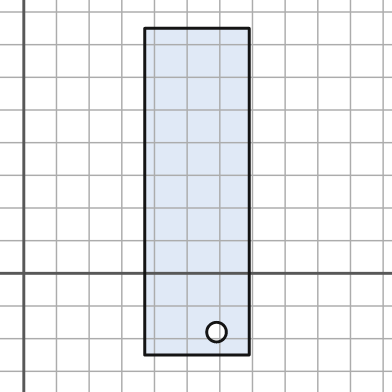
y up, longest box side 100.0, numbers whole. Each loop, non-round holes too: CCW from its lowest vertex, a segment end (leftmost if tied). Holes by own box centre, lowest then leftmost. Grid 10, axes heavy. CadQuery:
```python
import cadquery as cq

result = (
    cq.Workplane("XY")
    .moveTo(37.0, -25.0)
    .lineTo(69.0, -25.0)
    .lineTo(69.0, 75.0)
    .lineTo(37.0, 75.0)
    .close()
    .moveTo(59.0, -18.0)
    .circle(3.0)
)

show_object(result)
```